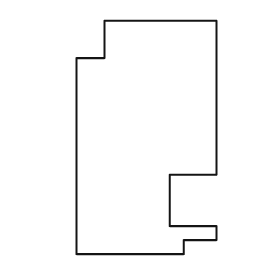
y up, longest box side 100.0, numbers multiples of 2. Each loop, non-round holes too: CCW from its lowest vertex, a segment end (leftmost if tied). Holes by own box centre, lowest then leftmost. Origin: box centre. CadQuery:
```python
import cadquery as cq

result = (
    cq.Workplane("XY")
    .moveTo(-30.0, -50.0)
    .lineTo(16.0, -50.0)
    .lineTo(16.0, -44.0)
    .lineTo(30.0, -44.0)
    .lineTo(30.0, -38.0)
    .lineTo(10.0, -38.0)
    .lineTo(10.0, -16.0)
    .lineTo(30.0, -16.0)
    .lineTo(30.0, 50.0)
    .lineTo(-18.0, 50.0)
    .lineTo(-18.0, 34.0)
    .lineTo(-30.0, 34.0)
    .close()
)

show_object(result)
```